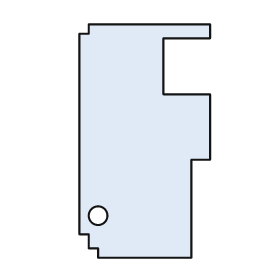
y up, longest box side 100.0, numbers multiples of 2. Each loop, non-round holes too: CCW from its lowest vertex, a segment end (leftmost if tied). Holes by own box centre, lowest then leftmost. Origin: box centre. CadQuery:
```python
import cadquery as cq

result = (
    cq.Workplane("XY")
    .moveTo(-20.0, -50.0)
    .lineTo(20.0, -50.0)
    .lineTo(20.0, -8.0)
    .lineTo(28.0, -8.0)
    .lineTo(28.0, 20.0)
    .lineTo(8.0, 20.0)
    .lineTo(8.0, 44.0)
    .lineTo(28.0, 44.0)
    .lineTo(28.0, 50.0)
    .lineTo(-24.0, 50.0)
    .lineTo(-24.0, 46.0)
    .lineTo(-28.0, 46.0)
    .lineTo(-28.0, -40.0)
    .lineTo(-24.0, -40.0)
    .lineTo(-24.0, -46.0)
    .lineTo(-20.0, -46.0)
    .close()
    .moveTo(-20.0, -32.0)
    .circle(4.0)
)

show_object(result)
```